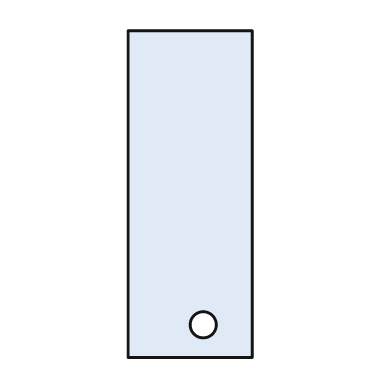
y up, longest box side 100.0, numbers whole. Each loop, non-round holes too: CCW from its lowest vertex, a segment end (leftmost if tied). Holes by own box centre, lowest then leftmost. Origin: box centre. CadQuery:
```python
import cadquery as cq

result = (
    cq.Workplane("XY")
    .moveTo(-19.0, -50.0)
    .lineTo(19.0, -50.0)
    .lineTo(19.0, 50.0)
    .lineTo(-19.0, 50.0)
    .close()
    .moveTo(4.0, -40.0)
    .circle(4.0)
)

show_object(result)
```